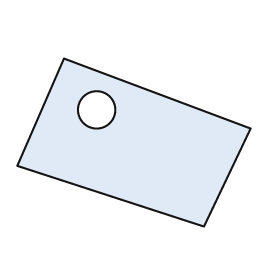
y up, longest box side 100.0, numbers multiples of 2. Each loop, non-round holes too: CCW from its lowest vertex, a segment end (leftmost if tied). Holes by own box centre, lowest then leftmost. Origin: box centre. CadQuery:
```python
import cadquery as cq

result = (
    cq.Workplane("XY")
    .moveTo(30.0, -36.0)
    .lineTo(50.0, 6.0)
    .lineTo(-30.0, 36.0)
    .lineTo(-50.0, -10.0)
    .close()
    .moveTo(-16.0, 14.0)
    .circle(8.0)
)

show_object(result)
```